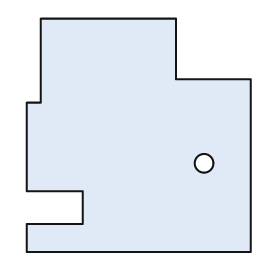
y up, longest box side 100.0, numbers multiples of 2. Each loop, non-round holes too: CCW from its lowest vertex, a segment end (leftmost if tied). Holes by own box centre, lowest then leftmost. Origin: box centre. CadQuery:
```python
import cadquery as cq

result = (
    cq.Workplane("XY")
    .moveTo(-48.0, -50.0)
    .lineTo(48.0, -50.0)
    .lineTo(48.0, 24.0)
    .lineTo(16.0, 24.0)
    .lineTo(16.0, 50.0)
    .lineTo(-42.0, 50.0)
    .lineTo(-42.0, 14.0)
    .lineTo(-48.0, 14.0)
    .lineTo(-48.0, -24.0)
    .lineTo(-24.0, -24.0)
    .lineTo(-24.0, -38.0)
    .lineTo(-48.0, -38.0)
    .close()
    .moveTo(28.0, -12.0)
    .circle(4.0)
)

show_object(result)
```